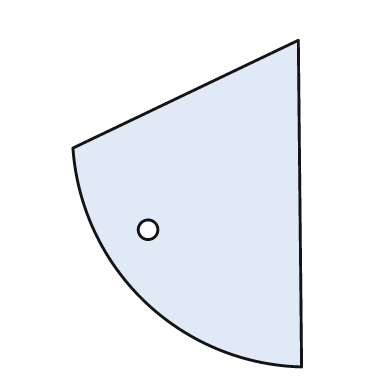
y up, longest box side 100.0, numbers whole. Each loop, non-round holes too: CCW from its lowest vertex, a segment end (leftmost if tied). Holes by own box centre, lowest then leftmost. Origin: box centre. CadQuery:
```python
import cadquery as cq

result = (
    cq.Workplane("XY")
    .moveTo(35.0, -50.0)
    .lineTo(34.0, 50.0)
    .lineTo(-35.0, 17.0)
    .threePointArc((-13.0, -30.0), (35.0, -50.0))
    .close()
    .moveTo(-12.0, -8.0)
    .circle(3.0)
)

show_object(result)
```